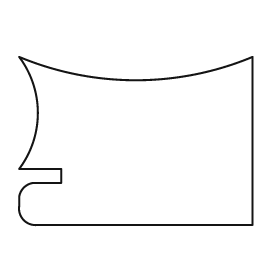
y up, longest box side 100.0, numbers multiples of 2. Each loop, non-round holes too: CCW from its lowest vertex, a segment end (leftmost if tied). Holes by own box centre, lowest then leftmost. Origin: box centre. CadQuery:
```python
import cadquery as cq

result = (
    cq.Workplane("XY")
    .moveTo(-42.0, -36.0)
    .lineTo(50.0, -36.0)
    .lineTo(50.0, 36.0)
    .threePointArc((0.0, 26.0), (-50.0, 36.0))
    .threePointArc((-42.0, 12.0), (-50.0, -12.0))
    .lineTo(-32.0, -12.0)
    .lineTo(-32.0, -18.0)
    .lineTo(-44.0, -18.0)
    .threePointArc((-48.0, -20.0), (-50.0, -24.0))
    .lineTo(-50.0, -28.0)
    .threePointArc((-48.0, -34.0), (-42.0, -36.0))
    .close()
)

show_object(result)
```